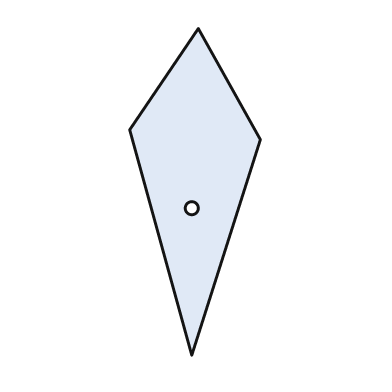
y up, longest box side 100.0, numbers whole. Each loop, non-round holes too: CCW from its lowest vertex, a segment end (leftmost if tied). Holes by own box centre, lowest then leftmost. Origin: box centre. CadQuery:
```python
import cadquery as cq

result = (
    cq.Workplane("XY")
    .moveTo(-1.0, -50.0)
    .lineTo(20.0, 16.0)
    .lineTo(1.0, 50.0)
    .lineTo(-20.0, 19.0)
    .close()
    .moveTo(-1.0, -5.0)
    .circle(2.0)
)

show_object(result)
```